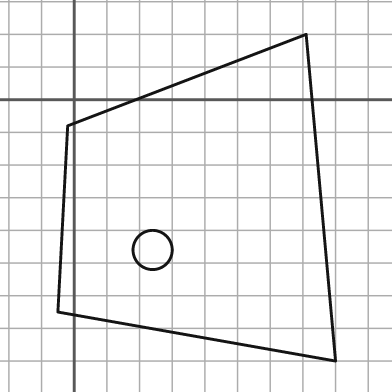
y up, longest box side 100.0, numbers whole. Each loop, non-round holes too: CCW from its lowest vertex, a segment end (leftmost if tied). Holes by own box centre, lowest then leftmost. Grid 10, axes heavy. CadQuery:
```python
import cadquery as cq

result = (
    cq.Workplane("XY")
    .moveTo(80.0, -80.0)
    .lineTo(71.0, 20.0)
    .lineTo(-2.0, -8.0)
    .lineTo(-5.0, -65.0)
    .close()
    .moveTo(24.0, -46.0)
    .circle(6.0)
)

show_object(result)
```